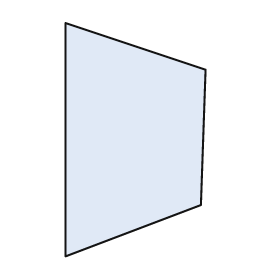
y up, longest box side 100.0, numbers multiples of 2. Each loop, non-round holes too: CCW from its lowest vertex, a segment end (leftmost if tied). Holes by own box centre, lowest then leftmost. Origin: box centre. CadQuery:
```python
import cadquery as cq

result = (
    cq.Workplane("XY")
    .moveTo(-30.0, -50.0)
    .lineTo(28.0, -28.0)
    .lineTo(30.0, 30.0)
    .lineTo(-30.0, 50.0)
    .close()
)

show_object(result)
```